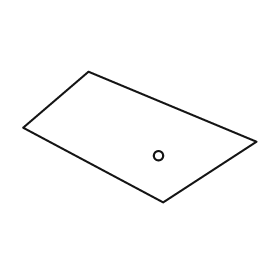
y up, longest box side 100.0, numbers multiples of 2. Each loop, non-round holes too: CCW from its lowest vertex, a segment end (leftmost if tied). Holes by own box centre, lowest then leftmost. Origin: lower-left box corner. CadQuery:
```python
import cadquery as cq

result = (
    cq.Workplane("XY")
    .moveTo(60.0, 0.0)
    .lineTo(100.0, 26.0)
    .lineTo(28.0, 56.0)
    .lineTo(0.0, 32.0)
    .close()
    .moveTo(58.0, 20.0)
    .circle(2.0)
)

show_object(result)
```